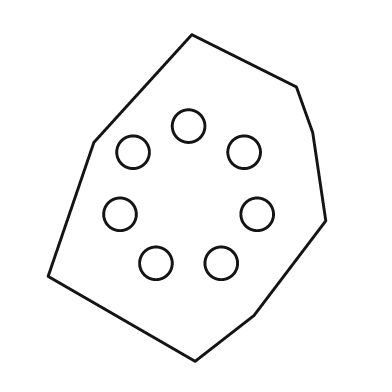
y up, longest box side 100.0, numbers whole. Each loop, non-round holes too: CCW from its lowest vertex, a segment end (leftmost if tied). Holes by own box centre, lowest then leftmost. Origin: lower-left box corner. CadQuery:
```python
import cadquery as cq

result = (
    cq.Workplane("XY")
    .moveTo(45.0, 0.0)
    .lineTo(63.0, 14.0)
    .lineTo(85.0, 43.0)
    .lineTo(81.0, 70.0)
    .lineTo(76.0, 84.0)
    .lineTo(44.0, 100.0)
    .lineTo(14.0, 67.0)
    .lineTo(0.0, 26.0)
    .close()
    .moveTo(33.0, 30.0)
    .circle(5.0)
    .moveTo(53.0, 30.0)
    .circle(5.0)
    .moveTo(22.0, 45.0)
    .circle(5.0)
    .moveTo(64.0, 45.0)
    .circle(5.0)
    .moveTo(26.0, 64.0)
    .circle(5.0)
    .moveTo(60.0, 64.0)
    .circle(5.0)
    .moveTo(43.0, 72.0)
    .circle(5.0)
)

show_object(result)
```